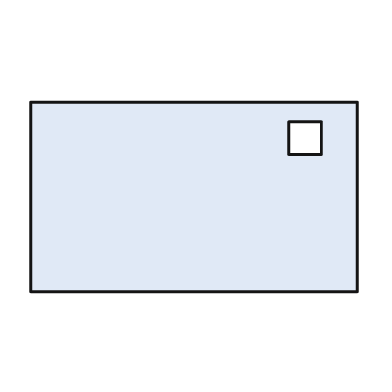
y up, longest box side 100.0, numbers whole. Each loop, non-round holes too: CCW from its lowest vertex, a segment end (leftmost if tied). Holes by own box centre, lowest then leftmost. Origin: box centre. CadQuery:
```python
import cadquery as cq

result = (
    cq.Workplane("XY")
    .moveTo(-50.0, -29.0)
    .lineTo(50.0, -29.0)
    .lineTo(50.0, 29.0)
    .lineTo(-50.0, 29.0)
    .close()
    .moveTo(29.0, 13.0)
    .lineTo(39.0, 13.0)
    .lineTo(39.0, 23.0)
    .lineTo(29.0, 23.0)
    .close()
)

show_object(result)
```